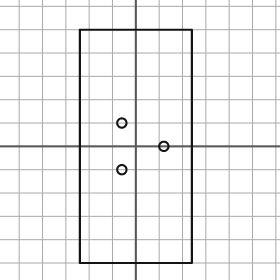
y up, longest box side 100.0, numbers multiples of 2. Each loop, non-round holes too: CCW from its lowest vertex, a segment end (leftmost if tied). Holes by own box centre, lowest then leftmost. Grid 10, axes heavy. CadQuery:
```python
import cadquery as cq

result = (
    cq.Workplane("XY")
    .moveTo(-24.0, -50.0)
    .lineTo(24.0, -50.0)
    .lineTo(24.0, 50.0)
    .lineTo(-24.0, 50.0)
    .close()
    .moveTo(-6.0, -10.0)
    .circle(2.0)
    .moveTo(12.0, 0.0)
    .circle(2.0)
    .moveTo(-6.0, 10.0)
    .circle(2.0)
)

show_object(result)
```